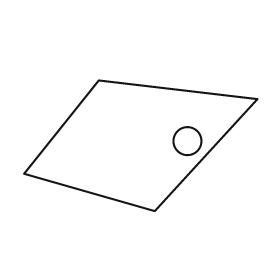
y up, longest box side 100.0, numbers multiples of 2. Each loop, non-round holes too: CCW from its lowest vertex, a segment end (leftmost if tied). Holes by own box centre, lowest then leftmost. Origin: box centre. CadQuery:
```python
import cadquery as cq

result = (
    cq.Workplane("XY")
    .moveTo(6.0, -28.0)
    .lineTo(50.0, 20.0)
    .lineTo(-18.0, 28.0)
    .lineTo(-50.0, -12.0)
    .close()
    .moveTo(20.0, 2.0)
    .circle(6.0)
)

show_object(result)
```